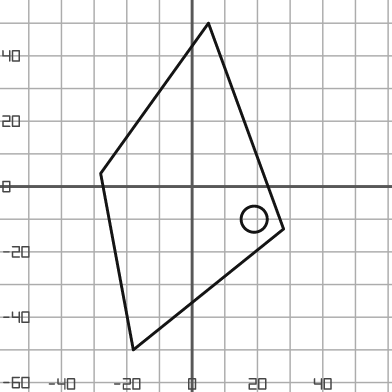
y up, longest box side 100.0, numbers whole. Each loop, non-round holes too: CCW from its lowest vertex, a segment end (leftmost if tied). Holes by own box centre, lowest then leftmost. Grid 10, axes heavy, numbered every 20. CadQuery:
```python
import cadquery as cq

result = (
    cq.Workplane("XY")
    .moveTo(-18.0, -50.0)
    .lineTo(28.0, -13.0)
    .lineTo(5.0, 50.0)
    .lineTo(-28.0, 4.0)
    .close()
    .moveTo(19.0, -10.0)
    .circle(4.0)
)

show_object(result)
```